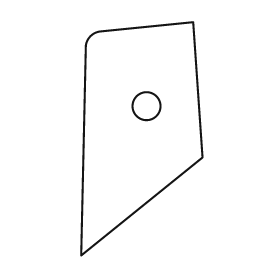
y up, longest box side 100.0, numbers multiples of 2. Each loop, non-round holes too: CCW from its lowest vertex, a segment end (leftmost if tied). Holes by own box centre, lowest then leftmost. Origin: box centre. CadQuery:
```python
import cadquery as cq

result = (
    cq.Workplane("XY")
    .moveTo(-26.0, -50.0)
    .lineTo(26.0, -8.0)
    .lineTo(22.0, 50.0)
    .lineTo(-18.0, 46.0)
    .threePointArc((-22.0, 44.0), (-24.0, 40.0))
    .close()
    .moveTo(2.0, 14.0)
    .circle(6.0)
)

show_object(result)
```